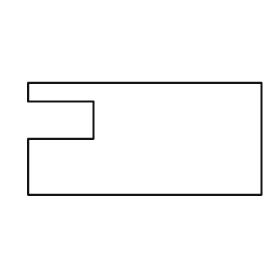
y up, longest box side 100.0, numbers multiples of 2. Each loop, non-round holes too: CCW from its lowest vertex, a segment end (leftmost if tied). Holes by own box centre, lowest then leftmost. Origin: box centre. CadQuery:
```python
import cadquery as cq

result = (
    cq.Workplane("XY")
    .moveTo(-50.0, -24.0)
    .lineTo(50.0, -24.0)
    .lineTo(50.0, 24.0)
    .lineTo(-50.0, 24.0)
    .lineTo(-50.0, 16.0)
    .lineTo(-22.0, 16.0)
    .lineTo(-22.0, 0.0)
    .lineTo(-50.0, 0.0)
    .close()
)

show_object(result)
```